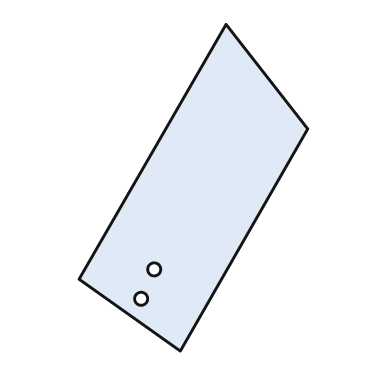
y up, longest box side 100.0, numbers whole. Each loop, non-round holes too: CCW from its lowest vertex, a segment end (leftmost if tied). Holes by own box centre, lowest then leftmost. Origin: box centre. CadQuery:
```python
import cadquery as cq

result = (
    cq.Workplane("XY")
    .moveTo(-4.0, -50.0)
    .lineTo(35.0, 18.0)
    .lineTo(10.0, 50.0)
    .lineTo(-35.0, -28.0)
    .close()
    .moveTo(-16.0, -34.0)
    .circle(2.0)
    .moveTo(-12.0, -25.0)
    .circle(2.0)
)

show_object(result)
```